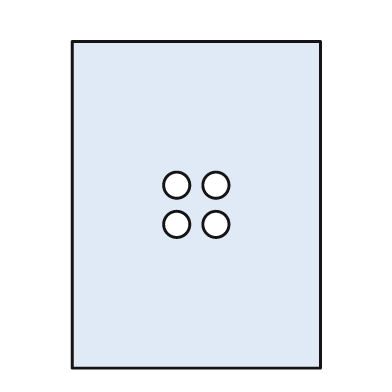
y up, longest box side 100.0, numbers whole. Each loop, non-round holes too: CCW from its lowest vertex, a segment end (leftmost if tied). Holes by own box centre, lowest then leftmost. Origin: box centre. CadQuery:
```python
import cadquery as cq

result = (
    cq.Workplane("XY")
    .moveTo(-38.0, -50.0)
    .lineTo(38.0, -50.0)
    .lineTo(38.0, 50.0)
    .lineTo(-38.0, 50.0)
    .close()
    .moveTo(-6.0, -6.0)
    .circle(4.0)
    .moveTo(6.0, -6.0)
    .circle(4.0)
    .moveTo(-6.0, 6.0)
    .circle(4.0)
    .moveTo(6.0, 6.0)
    .circle(4.0)
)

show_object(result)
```